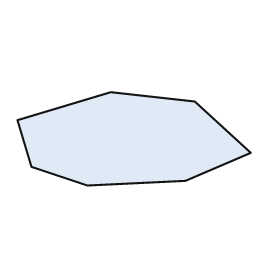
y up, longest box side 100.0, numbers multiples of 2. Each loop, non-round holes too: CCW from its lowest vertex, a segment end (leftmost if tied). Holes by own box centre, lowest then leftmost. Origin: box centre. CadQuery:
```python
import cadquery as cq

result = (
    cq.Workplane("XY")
    .moveTo(-20.0, -20.0)
    .lineTo(22.0, -18.0)
    .lineTo(50.0, -6.0)
    .lineTo(26.0, 16.0)
    .lineTo(-10.0, 20.0)
    .lineTo(-50.0, 8.0)
    .lineTo(-44.0, -12.0)
    .close()
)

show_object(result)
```